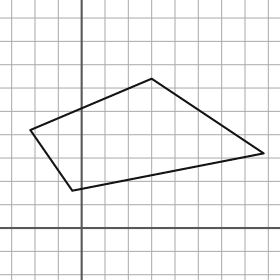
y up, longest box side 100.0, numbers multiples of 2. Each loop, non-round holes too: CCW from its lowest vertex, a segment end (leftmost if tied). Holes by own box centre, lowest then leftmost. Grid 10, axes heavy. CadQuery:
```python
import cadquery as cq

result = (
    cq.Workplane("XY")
    .moveTo(-4.0, 16.0)
    .lineTo(78.0, 32.0)
    .lineTo(30.0, 64.0)
    .lineTo(-22.0, 42.0)
    .close()
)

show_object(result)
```